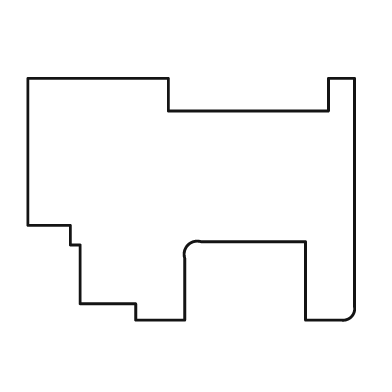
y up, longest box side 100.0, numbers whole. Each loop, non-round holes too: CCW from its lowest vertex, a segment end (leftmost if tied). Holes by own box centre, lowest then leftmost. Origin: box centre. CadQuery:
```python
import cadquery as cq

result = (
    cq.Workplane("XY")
    .moveTo(-17.0, -37.0)
    .lineTo(-2.0, -37.0)
    .lineTo(-2.0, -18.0)
    .threePointArc((-1.0, -14.0), (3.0, -13.0))
    .lineTo(35.0, -13.0)
    .lineTo(35.0, -37.0)
    .lineTo(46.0, -37.0)
    .threePointArc((49.0, -36.0), (50.0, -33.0))
    .lineTo(50.0, 37.0)
    .lineTo(42.0, 37.0)
    .lineTo(42.0, 27.0)
    .lineTo(-7.0, 27.0)
    .lineTo(-7.0, 37.0)
    .lineTo(-50.0, 37.0)
    .lineTo(-50.0, -8.0)
    .lineTo(-37.0, -8.0)
    .lineTo(-37.0, -14.0)
    .lineTo(-34.0, -14.0)
    .lineTo(-34.0, -32.0)
    .lineTo(-17.0, -32.0)
    .close()
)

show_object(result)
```